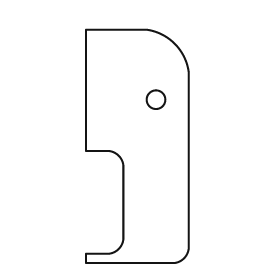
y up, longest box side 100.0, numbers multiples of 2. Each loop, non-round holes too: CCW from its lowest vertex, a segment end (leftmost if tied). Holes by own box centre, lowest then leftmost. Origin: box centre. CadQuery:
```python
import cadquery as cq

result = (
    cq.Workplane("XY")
    .moveTo(-22.0, -50.0)
    .lineTo(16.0, -50.0)
    .threePointArc((20.0, -48.0), (22.0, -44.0))
    .lineTo(22.0, 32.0)
    .threePointArc((16.0, 44.0), (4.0, 50.0))
    .lineTo(-22.0, 50.0)
    .lineTo(-22.0, -2.0)
    .lineTo(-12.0, -2.0)
    .threePointArc((-8.0, -4.0), (-6.0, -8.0))
    .lineTo(-6.0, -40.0)
    .threePointArc((-8.0, -44.0), (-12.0, -46.0))
    .lineTo(-22.0, -46.0)
    .close()
    .moveTo(8.0, 20.0)
    .circle(4.0)
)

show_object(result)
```